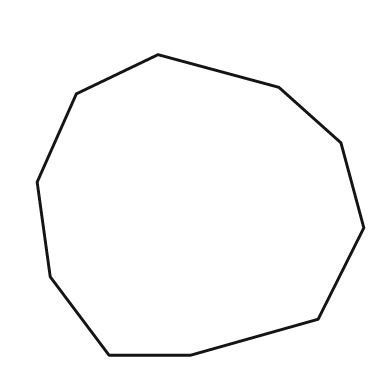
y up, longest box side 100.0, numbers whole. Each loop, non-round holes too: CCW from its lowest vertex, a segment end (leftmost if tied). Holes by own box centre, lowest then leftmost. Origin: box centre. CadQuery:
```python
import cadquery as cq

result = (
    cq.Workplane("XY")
    .moveTo(-28.0, -46.0)
    .lineTo(-3.0, -46.0)
    .lineTo(36.0, -35.0)
    .lineTo(50.0, -7.0)
    .lineTo(43.0, 19.0)
    .lineTo(24.0, 36.0)
    .lineTo(-13.0, 46.0)
    .lineTo(-38.0, 34.0)
    .lineTo(-50.0, 7.0)
    .lineTo(-46.0, -22.0)
    .close()
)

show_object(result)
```